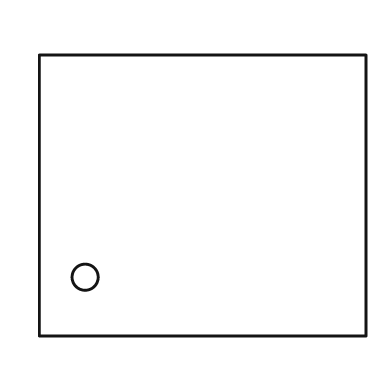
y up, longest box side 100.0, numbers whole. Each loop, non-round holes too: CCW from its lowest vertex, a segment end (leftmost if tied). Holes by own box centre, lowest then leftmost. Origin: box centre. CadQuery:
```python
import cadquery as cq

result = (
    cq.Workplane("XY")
    .moveTo(-50.0, -43.0)
    .lineTo(50.0, -43.0)
    .lineTo(50.0, 43.0)
    .lineTo(-50.0, 43.0)
    .close()
    .moveTo(-36.0, -25.0)
    .circle(4.0)
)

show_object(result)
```